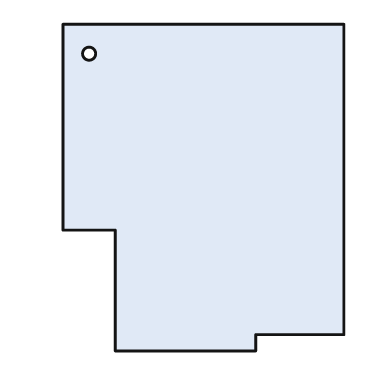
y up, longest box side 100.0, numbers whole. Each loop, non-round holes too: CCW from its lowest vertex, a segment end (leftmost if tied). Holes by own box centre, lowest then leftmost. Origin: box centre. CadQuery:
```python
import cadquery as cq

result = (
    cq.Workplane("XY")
    .moveTo(-27.0, -50.0)
    .lineTo(16.0, -50.0)
    .lineTo(16.0, -45.0)
    .lineTo(43.0, -45.0)
    .lineTo(43.0, 50.0)
    .lineTo(-43.0, 50.0)
    .lineTo(-43.0, -13.0)
    .lineTo(-27.0, -13.0)
    .close()
    .moveTo(-35.0, 41.0)
    .circle(2.0)
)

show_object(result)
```